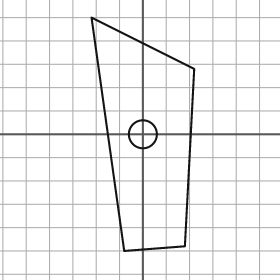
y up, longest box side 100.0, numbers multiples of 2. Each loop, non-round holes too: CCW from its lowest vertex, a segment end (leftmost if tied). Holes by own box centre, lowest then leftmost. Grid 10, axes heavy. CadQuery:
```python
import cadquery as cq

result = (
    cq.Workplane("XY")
    .moveTo(-8.0, -50.0)
    .lineTo(18.0, -48.0)
    .lineTo(22.0, 28.0)
    .lineTo(-22.0, 50.0)
    .close()
    .moveTo(0.0, 0.0)
    .circle(6.0)
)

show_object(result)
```